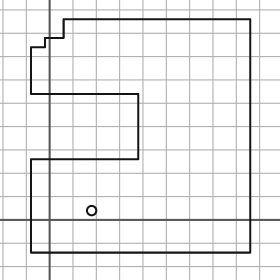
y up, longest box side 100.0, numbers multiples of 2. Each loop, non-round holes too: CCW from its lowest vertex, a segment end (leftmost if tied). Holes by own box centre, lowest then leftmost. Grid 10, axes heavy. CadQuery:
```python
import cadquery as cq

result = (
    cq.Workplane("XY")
    .moveTo(-8.0, -14.0)
    .lineTo(86.0, -14.0)
    .lineTo(86.0, 86.0)
    .lineTo(6.0, 86.0)
    .lineTo(6.0, 78.0)
    .lineTo(-2.0, 78.0)
    .lineTo(-2.0, 74.0)
    .lineTo(-8.0, 74.0)
    .lineTo(-8.0, 54.0)
    .lineTo(38.0, 54.0)
    .lineTo(38.0, 26.0)
    .lineTo(-8.0, 26.0)
    .close()
    .moveTo(18.0, 4.0)
    .circle(2.0)
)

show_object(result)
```